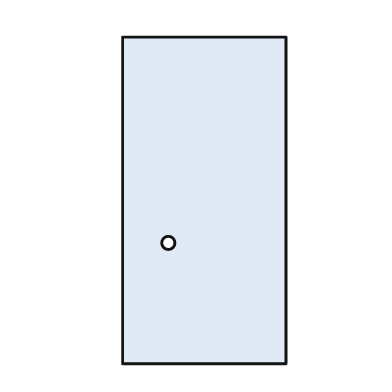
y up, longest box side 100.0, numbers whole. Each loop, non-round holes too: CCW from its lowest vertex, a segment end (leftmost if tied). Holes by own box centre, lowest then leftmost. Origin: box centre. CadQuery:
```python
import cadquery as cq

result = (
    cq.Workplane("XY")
    .moveTo(-25.0, -50.0)
    .lineTo(25.0, -50.0)
    .lineTo(25.0, 50.0)
    .lineTo(-25.0, 50.0)
    .close()
    .moveTo(-11.0, -13.0)
    .circle(2.0)
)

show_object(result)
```